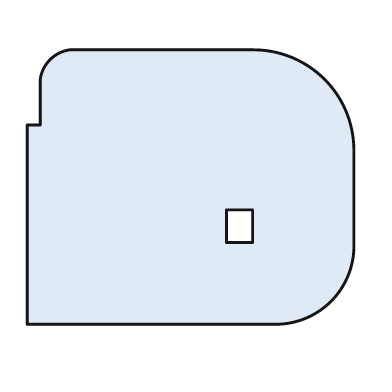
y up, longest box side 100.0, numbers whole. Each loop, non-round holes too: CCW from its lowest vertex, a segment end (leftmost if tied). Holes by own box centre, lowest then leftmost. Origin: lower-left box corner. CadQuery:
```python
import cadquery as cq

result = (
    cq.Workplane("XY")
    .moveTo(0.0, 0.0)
    .lineTo(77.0, 0.0)
    .threePointArc((93.0, 7.0), (100.0, 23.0))
    .lineTo(100.0, 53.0)
    .threePointArc((91.0, 75.0), (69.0, 84.0))
    .lineTo(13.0, 84.0)
    .threePointArc((7.0, 81.0), (4.0, 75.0))
    .lineTo(4.0, 61.0)
    .lineTo(0.0, 61.0)
    .close()
    .moveTo(61.0, 25.0)
    .lineTo(69.0, 25.0)
    .lineTo(69.0, 35.0)
    .lineTo(61.0, 35.0)
    .close()
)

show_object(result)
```